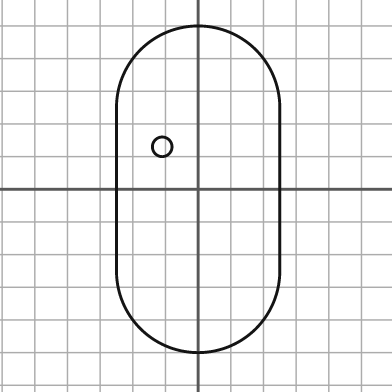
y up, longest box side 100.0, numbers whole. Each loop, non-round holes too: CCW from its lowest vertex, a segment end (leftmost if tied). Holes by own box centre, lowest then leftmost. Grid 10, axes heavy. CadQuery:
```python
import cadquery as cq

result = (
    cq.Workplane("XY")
    .moveTo(-25.0, -25.0)
    .threePointArc((0.0, -50.0), (25.0, -25.0))
    .lineTo(25.0, 25.0)
    .threePointArc((0.0, 50.0), (-25.0, 25.0))
    .close()
    .moveTo(-11.0, 13.0)
    .circle(3.0)
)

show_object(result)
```